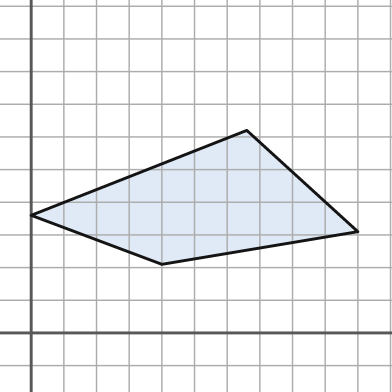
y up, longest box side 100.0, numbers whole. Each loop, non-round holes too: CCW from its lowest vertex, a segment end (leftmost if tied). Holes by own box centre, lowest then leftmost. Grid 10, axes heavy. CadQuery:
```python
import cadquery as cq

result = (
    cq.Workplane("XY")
    .moveTo(40.0, 21.0)
    .lineTo(100.0, 31.0)
    .lineTo(66.0, 62.0)
    .lineTo(0.0, 36.0)
    .close()
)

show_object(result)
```